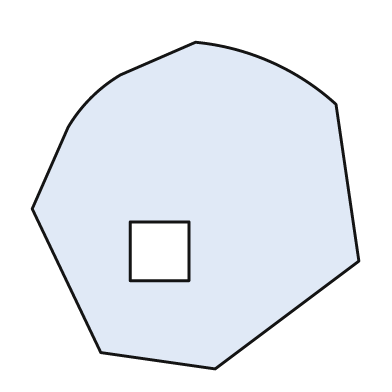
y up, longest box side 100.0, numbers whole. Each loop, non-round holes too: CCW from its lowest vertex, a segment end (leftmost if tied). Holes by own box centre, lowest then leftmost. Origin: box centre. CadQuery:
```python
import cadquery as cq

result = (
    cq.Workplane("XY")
    .moveTo(6.0, -50.0)
    .lineTo(50.0, -17.0)
    .lineTo(43.0, 31.0)
    .threePointArc((23.0, 44.0), (0.0, 50.0))
    .lineTo(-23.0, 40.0)
    .threePointArc((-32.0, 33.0), (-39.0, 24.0))
    .lineTo(-50.0, -1.0)
    .lineTo(-29.0, -45.0)
    .close()
    .moveTo(-20.0, -23.0)
    .lineTo(-2.0, -23.0)
    .lineTo(-2.0, -5.0)
    .lineTo(-20.0, -5.0)
    .close()
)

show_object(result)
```